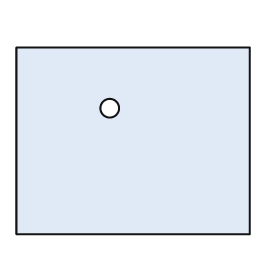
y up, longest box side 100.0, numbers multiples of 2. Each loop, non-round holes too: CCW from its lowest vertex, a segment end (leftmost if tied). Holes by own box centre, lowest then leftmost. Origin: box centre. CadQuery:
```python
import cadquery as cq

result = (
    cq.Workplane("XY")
    .moveTo(-50.0, -40.0)
    .lineTo(50.0, -40.0)
    .lineTo(50.0, 40.0)
    .lineTo(-50.0, 40.0)
    .close()
    .moveTo(-10.0, 14.0)
    .circle(4.0)
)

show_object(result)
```